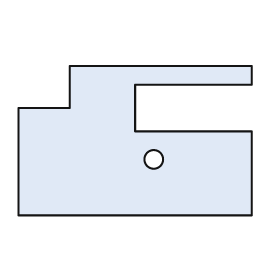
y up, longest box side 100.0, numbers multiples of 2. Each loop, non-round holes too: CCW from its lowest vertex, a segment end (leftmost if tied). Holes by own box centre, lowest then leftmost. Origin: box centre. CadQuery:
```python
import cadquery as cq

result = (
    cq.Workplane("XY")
    .moveTo(-50.0, -32.0)
    .lineTo(50.0, -32.0)
    .lineTo(50.0, 4.0)
    .lineTo(0.0, 4.0)
    .lineTo(0.0, 24.0)
    .lineTo(50.0, 24.0)
    .lineTo(50.0, 32.0)
    .lineTo(-28.0, 32.0)
    .lineTo(-28.0, 14.0)
    .lineTo(-50.0, 14.0)
    .close()
    .moveTo(8.0, -8.0)
    .circle(4.0)
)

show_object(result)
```